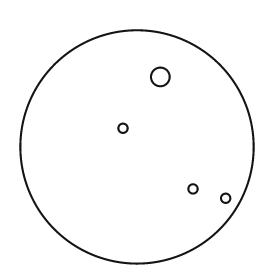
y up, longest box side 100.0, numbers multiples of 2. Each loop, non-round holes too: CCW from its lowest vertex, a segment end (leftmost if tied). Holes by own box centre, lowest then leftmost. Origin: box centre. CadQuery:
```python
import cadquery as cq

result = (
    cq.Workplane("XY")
    .moveTo(0.0, 0.0)
    .circle(50.0)
    .moveTo(38.0, -22.0)
    .circle(2.0)
    .moveTo(24.0, -18.0)
    .circle(2.0)
    .moveTo(-6.0, 8.0)
    .circle(2.0)
    .moveTo(10.0, 30.0)
    .circle(4.0)
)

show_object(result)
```